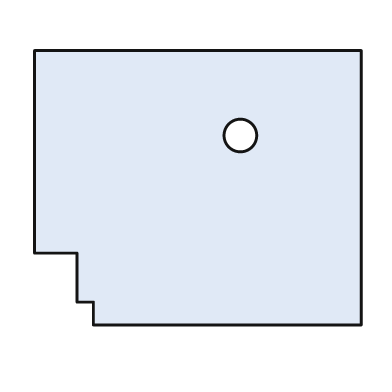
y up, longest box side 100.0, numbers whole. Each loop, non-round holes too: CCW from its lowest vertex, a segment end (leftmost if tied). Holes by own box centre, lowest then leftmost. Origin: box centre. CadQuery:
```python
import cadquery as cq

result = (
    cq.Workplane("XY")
    .moveTo(-32.0, -42.0)
    .lineTo(50.0, -42.0)
    .lineTo(50.0, 42.0)
    .lineTo(-50.0, 42.0)
    .lineTo(-50.0, -20.0)
    .lineTo(-37.0, -20.0)
    .lineTo(-37.0, -35.0)
    .lineTo(-32.0, -35.0)
    .close()
    .moveTo(13.0, 16.0)
    .circle(5.0)
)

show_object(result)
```